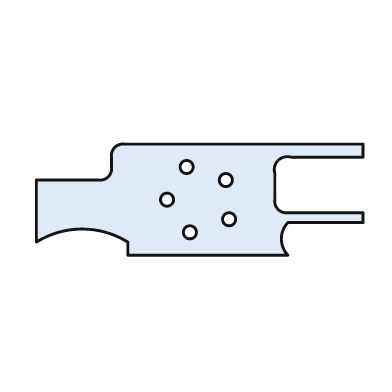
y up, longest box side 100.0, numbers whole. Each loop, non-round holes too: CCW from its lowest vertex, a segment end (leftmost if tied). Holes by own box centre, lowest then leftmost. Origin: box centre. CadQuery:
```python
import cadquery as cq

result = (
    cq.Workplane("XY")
    .moveTo(-22.0, -17.0)
    .lineTo(27.0, -17.0)
    .threePointArc((25.0, -12.0), (27.0, -7.0))
    .lineTo(50.0, -7.0)
    .lineTo(50.0, -4.0)
    .lineTo(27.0, -4.0)
    .threePointArc((24.0, -3.0), (23.0, 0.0))
    .lineTo(23.0, 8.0)
    .threePointArc((24.0, 12.0), (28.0, 13.0))
    .lineTo(50.0, 13.0)
    .lineTo(50.0, 17.0)
    .lineTo(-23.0, 17.0)
    .threePointArc((-26.0, 16.0), (-27.0, 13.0))
    .lineTo(-27.0, 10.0)
    .threePointArc((-28.0, 7.0), (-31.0, 6.0))
    .lineTo(-50.0, 6.0)
    .lineTo(-50.0, -13.0)
    .threePointArc((-36.0, -9.0), (-22.0, -13.0))
    .close()
    .moveTo(-3.0, -10.0)
    .circle(2.0)
    .moveTo(9.0, -6.0)
    .circle(2.0)
    .moveTo(-10.0, 0.0)
    .circle(2.0)
    .moveTo(8.0, 6.0)
    .circle(2.0)
    .moveTo(-4.0, 10.0)
    .circle(2.0)
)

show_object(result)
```